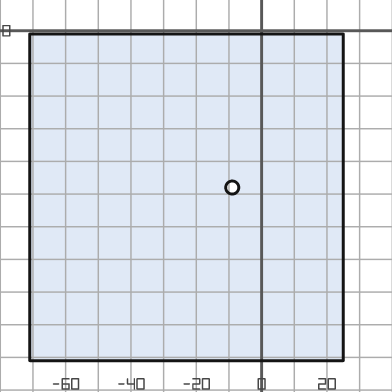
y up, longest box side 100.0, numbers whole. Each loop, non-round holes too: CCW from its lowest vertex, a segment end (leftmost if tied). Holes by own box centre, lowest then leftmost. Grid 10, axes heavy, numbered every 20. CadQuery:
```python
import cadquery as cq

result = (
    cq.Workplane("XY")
    .moveTo(-71.0, -101.0)
    .lineTo(25.0, -101.0)
    .lineTo(25.0, -1.0)
    .lineTo(-71.0, -1.0)
    .close()
    .moveTo(-9.0, -48.0)
    .circle(2.0)
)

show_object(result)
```